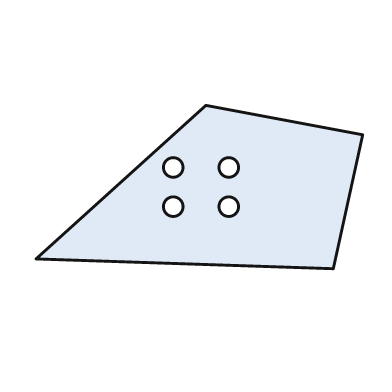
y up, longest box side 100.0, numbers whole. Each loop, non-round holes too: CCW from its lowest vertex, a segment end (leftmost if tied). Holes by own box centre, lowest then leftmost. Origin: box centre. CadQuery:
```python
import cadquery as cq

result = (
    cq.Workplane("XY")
    .moveTo(41.0, -25.0)
    .lineTo(50.0, 16.0)
    .lineTo(2.0, 25.0)
    .lineTo(-50.0, -22.0)
    .close()
    .moveTo(-8.0, -6.0)
    .circle(3.0)
    .moveTo(9.0, -6.0)
    .circle(3.0)
    .moveTo(-8.0, 6.0)
    .circle(3.0)
    .moveTo(9.0, 6.0)
    .circle(3.0)
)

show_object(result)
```